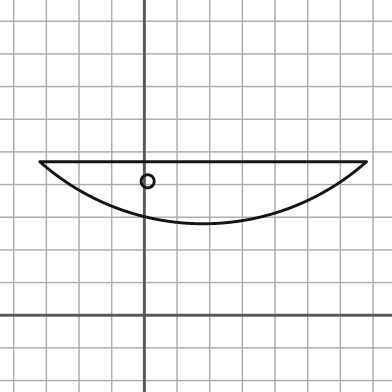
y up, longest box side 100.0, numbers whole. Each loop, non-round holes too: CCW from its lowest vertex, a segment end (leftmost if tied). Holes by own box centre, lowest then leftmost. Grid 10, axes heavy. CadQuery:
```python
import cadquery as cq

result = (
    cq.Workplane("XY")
    .moveTo(-32.0, 47.0)
    .threePointArc((18.0, 28.0), (68.0, 47.0))
    .close()
    .moveTo(1.0, 41.0)
    .circle(2.0)
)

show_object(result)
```